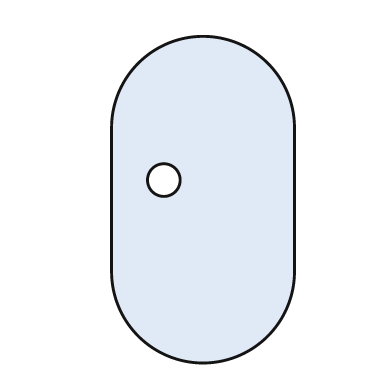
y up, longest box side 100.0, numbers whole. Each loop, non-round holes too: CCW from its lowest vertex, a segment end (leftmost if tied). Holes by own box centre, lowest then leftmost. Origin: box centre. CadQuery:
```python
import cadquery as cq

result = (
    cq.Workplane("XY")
    .moveTo(-28.0, -22.0)
    .threePointArc((0.0, -50.0), (28.0, -22.0))
    .lineTo(28.0, 22.0)
    .threePointArc((0.0, 50.0), (-28.0, 22.0))
    .close()
    .moveTo(-12.0, 6.0)
    .circle(5.0)
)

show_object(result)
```